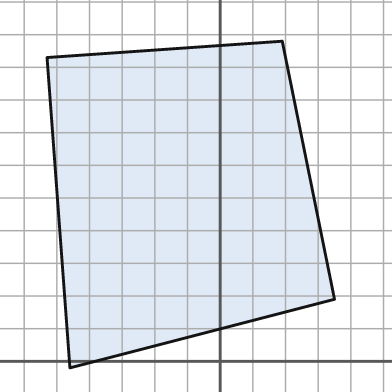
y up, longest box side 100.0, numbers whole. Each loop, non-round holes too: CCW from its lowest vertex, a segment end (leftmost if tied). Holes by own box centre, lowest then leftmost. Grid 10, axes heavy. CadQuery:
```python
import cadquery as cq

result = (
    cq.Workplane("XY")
    .moveTo(-46.0, -2.0)
    .lineTo(35.0, 19.0)
    .lineTo(19.0, 98.0)
    .lineTo(-53.0, 93.0)
    .close()
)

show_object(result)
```